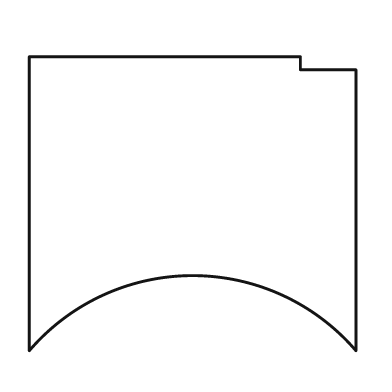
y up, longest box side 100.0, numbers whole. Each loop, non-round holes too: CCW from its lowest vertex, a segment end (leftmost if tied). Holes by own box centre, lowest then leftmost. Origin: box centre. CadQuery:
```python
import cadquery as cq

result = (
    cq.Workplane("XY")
    .moveTo(-50.0, -45.0)
    .threePointArc((0.0, -22.0), (50.0, -45.0))
    .lineTo(50.0, 41.0)
    .lineTo(33.0, 41.0)
    .lineTo(33.0, 45.0)
    .lineTo(-50.0, 45.0)
    .close()
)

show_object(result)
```